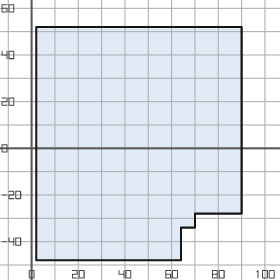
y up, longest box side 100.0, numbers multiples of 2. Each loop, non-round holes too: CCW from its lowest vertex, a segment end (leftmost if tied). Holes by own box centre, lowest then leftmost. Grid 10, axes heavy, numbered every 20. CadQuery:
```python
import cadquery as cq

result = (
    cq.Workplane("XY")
    .moveTo(2.0, -48.0)
    .lineTo(64.0, -48.0)
    .lineTo(64.0, -34.0)
    .lineTo(70.0, -34.0)
    .lineTo(70.0, -28.0)
    .lineTo(90.0, -28.0)
    .lineTo(90.0, 52.0)
    .lineTo(2.0, 52.0)
    .close()
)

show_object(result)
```